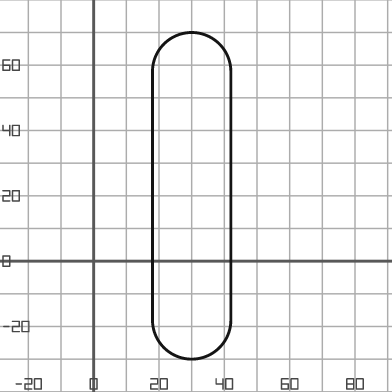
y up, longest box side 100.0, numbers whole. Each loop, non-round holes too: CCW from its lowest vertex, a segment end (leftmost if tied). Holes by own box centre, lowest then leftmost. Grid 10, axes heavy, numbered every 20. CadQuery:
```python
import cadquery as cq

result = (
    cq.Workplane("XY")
    .moveTo(18.0, -18.0)
    .threePointArc((30.0, -30.0), (42.0, -18.0))
    .lineTo(42.0, 58.0)
    .threePointArc((30.0, 70.0), (18.0, 58.0))
    .close()
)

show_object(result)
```